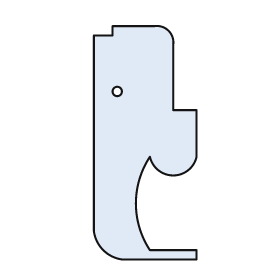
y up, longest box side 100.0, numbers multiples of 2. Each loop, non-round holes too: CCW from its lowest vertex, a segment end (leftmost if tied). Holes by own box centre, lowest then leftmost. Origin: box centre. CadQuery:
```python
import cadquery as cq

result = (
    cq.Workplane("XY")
    .moveTo(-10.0, -50.0)
    .lineTo(22.0, -50.0)
    .lineTo(22.0, -46.0)
    .lineTo(2.0, -46.0)
    .threePointArc((-4.0, -26.0), (2.0, -6.0))
    .threePointArc((12.0, -14.0), (22.0, -6.0))
    .lineTo(22.0, 14.0)
    .lineTo(12.0, 14.0)
    .lineTo(12.0, 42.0)
    .threePointArc((10.0, 48.0), (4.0, 50.0))
    .lineTo(-14.0, 50.0)
    .lineTo(-14.0, 46.0)
    .lineTo(-22.0, 46.0)
    .lineTo(-22.0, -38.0)
    .threePointArc((-18.0, -46.0), (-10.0, -50.0))
    .close()
    .moveTo(-12.0, 22.0)
    .circle(2.0)
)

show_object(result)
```